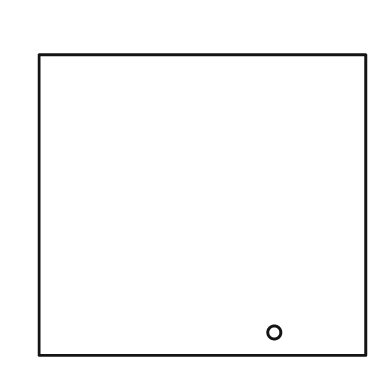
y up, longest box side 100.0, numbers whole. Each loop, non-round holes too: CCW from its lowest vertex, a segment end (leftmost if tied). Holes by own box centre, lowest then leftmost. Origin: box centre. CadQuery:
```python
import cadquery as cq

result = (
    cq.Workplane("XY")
    .moveTo(-50.0, -46.0)
    .lineTo(50.0, -46.0)
    .lineTo(50.0, 46.0)
    .lineTo(-50.0, 46.0)
    .close()
    .moveTo(22.0, -39.0)
    .circle(2.0)
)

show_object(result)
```